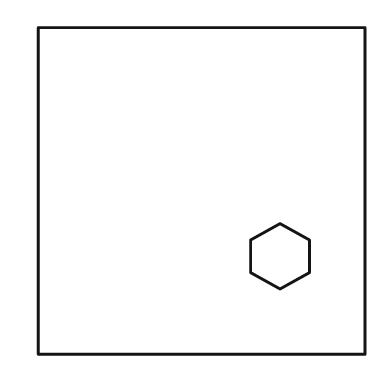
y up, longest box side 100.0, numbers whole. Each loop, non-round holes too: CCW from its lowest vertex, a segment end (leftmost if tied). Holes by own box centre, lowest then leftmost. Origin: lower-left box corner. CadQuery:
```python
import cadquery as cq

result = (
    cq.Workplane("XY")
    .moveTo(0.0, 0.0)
    .lineTo(100.0, 0.0)
    .lineTo(100.0, 100.0)
    .lineTo(0.0, 100.0)
    .close()
    .moveTo(74.0, 20.0)
    .lineTo(83.0, 25.0)
    .lineTo(83.0, 35.0)
    .lineTo(74.0, 40.0)
    .lineTo(65.0, 35.0)
    .lineTo(65.0, 25.0)
    .close()
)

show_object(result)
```